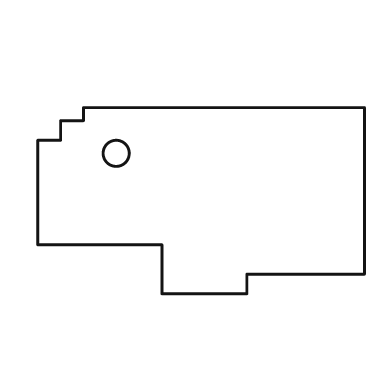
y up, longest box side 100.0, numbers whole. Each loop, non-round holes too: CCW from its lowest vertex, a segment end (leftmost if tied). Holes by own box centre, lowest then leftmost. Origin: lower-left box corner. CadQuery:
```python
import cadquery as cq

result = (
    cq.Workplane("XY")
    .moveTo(38.0, 0.0)
    .lineTo(64.0, 0.0)
    .lineTo(64.0, 6.0)
    .lineTo(100.0, 6.0)
    .lineTo(100.0, 57.0)
    .lineTo(14.0, 57.0)
    .lineTo(14.0, 53.0)
    .lineTo(7.0, 53.0)
    .lineTo(7.0, 47.0)
    .lineTo(0.0, 47.0)
    .lineTo(0.0, 15.0)
    .lineTo(38.0, 15.0)
    .close()
    .moveTo(24.0, 43.0)
    .circle(4.0)
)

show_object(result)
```